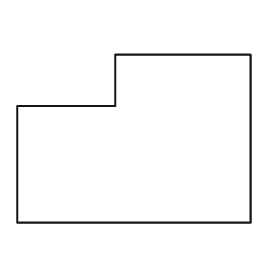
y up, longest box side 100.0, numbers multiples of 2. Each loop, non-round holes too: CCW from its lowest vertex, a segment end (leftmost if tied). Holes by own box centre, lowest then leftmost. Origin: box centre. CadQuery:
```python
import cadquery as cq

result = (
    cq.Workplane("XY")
    .moveTo(-50.0, -36.0)
    .lineTo(50.0, -36.0)
    .lineTo(50.0, 36.0)
    .lineTo(-8.0, 36.0)
    .lineTo(-8.0, 14.0)
    .lineTo(-50.0, 14.0)
    .close()
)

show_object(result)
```